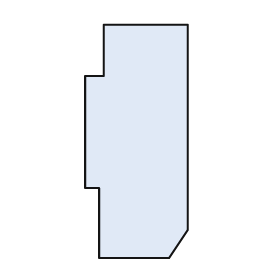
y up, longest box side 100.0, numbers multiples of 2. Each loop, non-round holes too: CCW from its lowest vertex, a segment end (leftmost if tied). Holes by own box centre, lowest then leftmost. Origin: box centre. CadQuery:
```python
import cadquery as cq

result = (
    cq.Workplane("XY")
    .moveTo(-16.0, -50.0)
    .lineTo(14.0, -50.0)
    .lineTo(22.0, -38.0)
    .lineTo(22.0, 50.0)
    .lineTo(-14.0, 50.0)
    .lineTo(-14.0, 28.0)
    .lineTo(-22.0, 28.0)
    .lineTo(-22.0, -20.0)
    .lineTo(-16.0, -20.0)
    .close()
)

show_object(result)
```